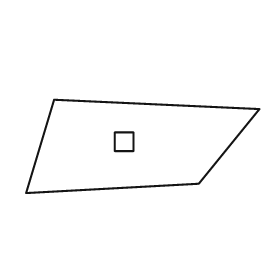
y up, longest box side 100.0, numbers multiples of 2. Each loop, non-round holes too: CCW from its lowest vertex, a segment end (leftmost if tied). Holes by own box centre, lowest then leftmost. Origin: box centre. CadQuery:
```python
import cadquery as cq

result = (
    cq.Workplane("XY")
    .moveTo(-50.0, -20.0)
    .lineTo(24.0, -16.0)
    .lineTo(50.0, 16.0)
    .lineTo(-38.0, 20.0)
    .close()
    .moveTo(-12.0, -2.0)
    .lineTo(-4.0, -2.0)
    .lineTo(-4.0, 6.0)
    .lineTo(-12.0, 6.0)
    .close()
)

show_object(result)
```